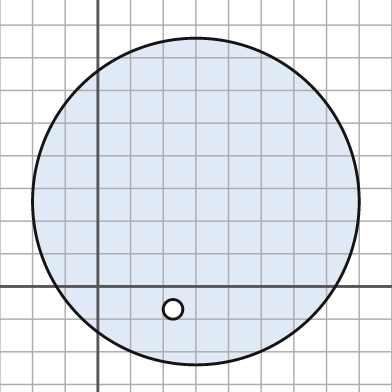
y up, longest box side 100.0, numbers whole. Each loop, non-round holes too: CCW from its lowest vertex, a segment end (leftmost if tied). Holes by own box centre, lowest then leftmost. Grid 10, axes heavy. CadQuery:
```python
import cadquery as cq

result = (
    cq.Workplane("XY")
    .moveTo(30.0, 26.0)
    .circle(50.0)
    .moveTo(23.0, -7.0)
    .circle(3.0)
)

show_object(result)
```